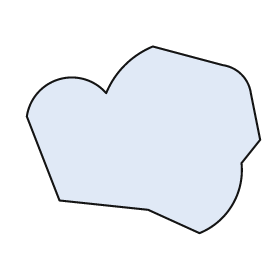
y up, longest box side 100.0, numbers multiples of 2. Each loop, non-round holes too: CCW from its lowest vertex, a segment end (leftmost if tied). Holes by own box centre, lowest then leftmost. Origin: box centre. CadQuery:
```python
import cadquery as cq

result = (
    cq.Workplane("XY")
    .moveTo(24.0, -40.0)
    .threePointArc((38.0, -28.0), (42.0, -10.0))
    .lineTo(50.0, 0.0)
    .lineTo(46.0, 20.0)
    .threePointArc((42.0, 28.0), (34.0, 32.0))
    .lineTo(4.0, 40.0)
    .threePointArc((-8.0, 32.0), (-16.0, 20.0))
    .threePointArc((-36.0, 26.0), (-50.0, 10.0))
    .lineTo(-36.0, -26.0)
    .lineTo(2.0, -30.0)
    .close()
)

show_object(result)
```